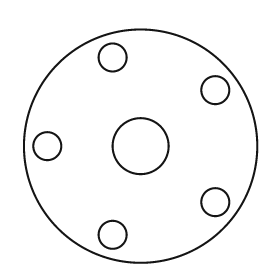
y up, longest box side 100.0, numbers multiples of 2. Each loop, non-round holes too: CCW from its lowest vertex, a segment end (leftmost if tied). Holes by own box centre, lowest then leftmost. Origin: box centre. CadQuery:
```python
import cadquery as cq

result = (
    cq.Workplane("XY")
    .moveTo(0.0, 0.0)
    .circle(50.0)
    .moveTo(-12.0, -38.0)
    .circle(6.0)
    .moveTo(32.0, -24.0)
    .circle(6.0)
    .moveTo(-40.0, 0.0)
    .circle(6.0)
    .moveTo(0.0, 0.0)
    .circle(12.0)
    .moveTo(32.0, 24.0)
    .circle(6.0)
    .moveTo(-12.0, 38.0)
    .circle(6.0)
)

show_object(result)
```